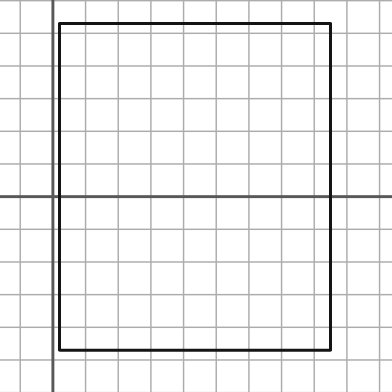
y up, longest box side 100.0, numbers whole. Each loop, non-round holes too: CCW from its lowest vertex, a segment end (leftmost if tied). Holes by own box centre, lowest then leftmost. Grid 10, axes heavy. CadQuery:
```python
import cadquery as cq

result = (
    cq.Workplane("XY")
    .moveTo(2.0, -47.0)
    .lineTo(85.0, -47.0)
    .lineTo(85.0, 53.0)
    .lineTo(2.0, 53.0)
    .close()
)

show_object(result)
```